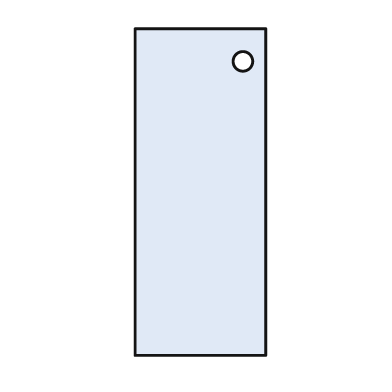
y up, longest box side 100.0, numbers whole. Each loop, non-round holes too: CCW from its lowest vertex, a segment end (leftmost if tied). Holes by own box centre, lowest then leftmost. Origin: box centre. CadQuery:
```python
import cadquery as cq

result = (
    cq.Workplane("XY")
    .moveTo(-20.0, -50.0)
    .lineTo(20.0, -50.0)
    .lineTo(20.0, 50.0)
    .lineTo(-20.0, 50.0)
    .close()
    .moveTo(13.0, 40.0)
    .circle(3.0)
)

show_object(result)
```